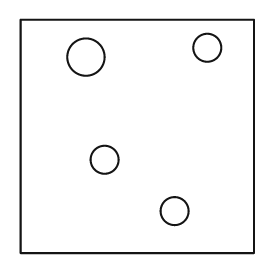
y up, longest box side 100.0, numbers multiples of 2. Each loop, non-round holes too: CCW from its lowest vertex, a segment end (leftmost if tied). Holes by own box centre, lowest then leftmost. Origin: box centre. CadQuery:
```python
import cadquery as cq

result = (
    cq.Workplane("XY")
    .moveTo(-50.0, -50.0)
    .lineTo(50.0, -50.0)
    .lineTo(50.0, 50.0)
    .lineTo(-50.0, 50.0)
    .close()
    .moveTo(16.0, -32.0)
    .circle(6.0)
    .moveTo(-14.0, -10.0)
    .circle(6.0)
    .moveTo(-22.0, 34.0)
    .circle(8.0)
    .moveTo(30.0, 38.0)
    .circle(6.0)
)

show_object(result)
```